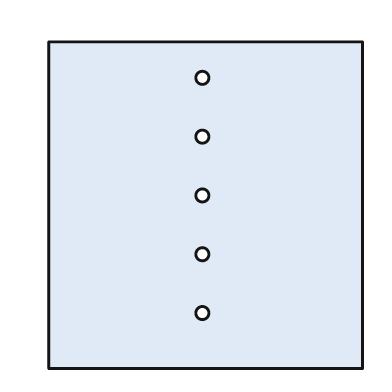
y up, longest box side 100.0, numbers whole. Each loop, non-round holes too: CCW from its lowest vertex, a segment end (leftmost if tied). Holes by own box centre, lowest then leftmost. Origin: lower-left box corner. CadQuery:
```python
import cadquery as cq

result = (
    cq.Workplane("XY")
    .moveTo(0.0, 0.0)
    .lineTo(96.0, 0.0)
    .lineTo(96.0, 100.0)
    .lineTo(0.0, 100.0)
    .close()
    .moveTo(47.0, 17.0)
    .circle(2.0)
    .moveTo(47.0, 35.0)
    .circle(2.0)
    .moveTo(47.0, 53.0)
    .circle(2.0)
    .moveTo(47.0, 71.0)
    .circle(2.0)
    .moveTo(47.0, 89.0)
    .circle(2.0)
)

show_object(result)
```